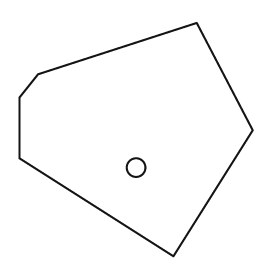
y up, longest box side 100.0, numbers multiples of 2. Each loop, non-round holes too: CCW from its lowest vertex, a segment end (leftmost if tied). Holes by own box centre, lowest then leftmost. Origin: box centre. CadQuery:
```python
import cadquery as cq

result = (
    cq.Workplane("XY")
    .moveTo(16.0, -50.0)
    .lineTo(50.0, 4.0)
    .lineTo(26.0, 50.0)
    .lineTo(-42.0, 28.0)
    .lineTo(-50.0, 18.0)
    .lineTo(-50.0, -8.0)
    .close()
    .moveTo(0.0, -12.0)
    .circle(4.0)
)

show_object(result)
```